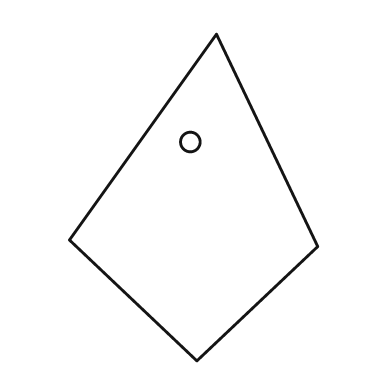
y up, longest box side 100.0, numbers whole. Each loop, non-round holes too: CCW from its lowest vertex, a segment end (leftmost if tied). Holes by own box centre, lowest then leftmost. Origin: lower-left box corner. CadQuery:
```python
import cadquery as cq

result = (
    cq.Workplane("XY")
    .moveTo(39.0, 0.0)
    .lineTo(76.0, 35.0)
    .lineTo(45.0, 100.0)
    .lineTo(0.0, 37.0)
    .close()
    .moveTo(37.0, 67.0)
    .circle(3.0)
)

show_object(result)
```